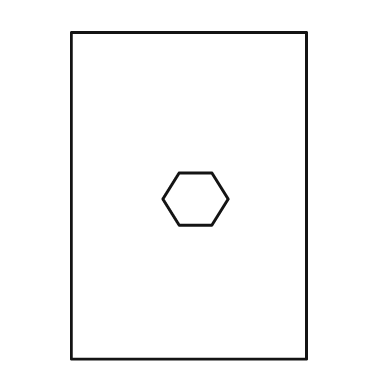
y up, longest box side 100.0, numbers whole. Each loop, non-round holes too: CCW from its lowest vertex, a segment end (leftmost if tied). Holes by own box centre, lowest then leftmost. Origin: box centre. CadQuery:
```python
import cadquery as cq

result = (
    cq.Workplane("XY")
    .moveTo(-36.0, -50.0)
    .lineTo(36.0, -50.0)
    .lineTo(36.0, 50.0)
    .lineTo(-36.0, 50.0)
    .close()
    .moveTo(-3.0, -9.0)
    .lineTo(7.0, -9.0)
    .lineTo(12.0, -1.0)
    .lineTo(7.0, 7.0)
    .lineTo(-3.0, 7.0)
    .lineTo(-8.0, -1.0)
    .close()
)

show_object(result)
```